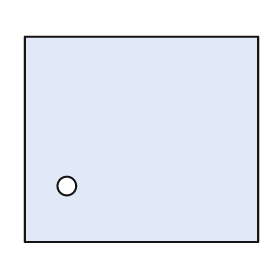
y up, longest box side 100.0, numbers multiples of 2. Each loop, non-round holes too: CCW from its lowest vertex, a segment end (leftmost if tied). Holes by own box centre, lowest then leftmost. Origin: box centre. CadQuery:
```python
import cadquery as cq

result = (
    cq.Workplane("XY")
    .moveTo(-50.0, -44.0)
    .lineTo(50.0, -44.0)
    .lineTo(50.0, 44.0)
    .lineTo(-50.0, 44.0)
    .close()
    .moveTo(-32.0, -20.0)
    .circle(4.0)
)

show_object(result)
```